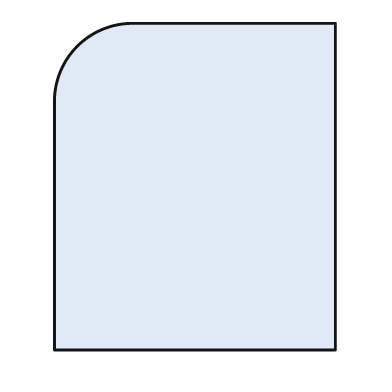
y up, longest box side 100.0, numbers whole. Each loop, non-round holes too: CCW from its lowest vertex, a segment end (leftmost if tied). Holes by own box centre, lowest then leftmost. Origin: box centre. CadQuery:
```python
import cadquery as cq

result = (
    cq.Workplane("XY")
    .moveTo(-43.0, -50.0)
    .lineTo(43.0, -50.0)
    .lineTo(43.0, 50.0)
    .lineTo(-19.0, 50.0)
    .threePointArc((-36.0, 43.0), (-43.0, 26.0))
    .close()
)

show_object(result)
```